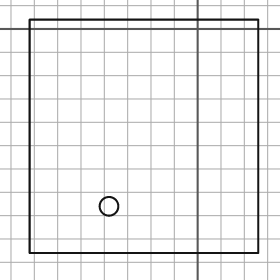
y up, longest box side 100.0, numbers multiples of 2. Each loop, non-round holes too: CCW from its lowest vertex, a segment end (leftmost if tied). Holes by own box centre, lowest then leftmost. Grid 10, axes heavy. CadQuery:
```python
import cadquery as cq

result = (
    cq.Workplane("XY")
    .moveTo(-72.0, -96.0)
    .lineTo(26.0, -96.0)
    .lineTo(26.0, 4.0)
    .lineTo(-72.0, 4.0)
    .close()
    .moveTo(-38.0, -76.0)
    .circle(4.0)
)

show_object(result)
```